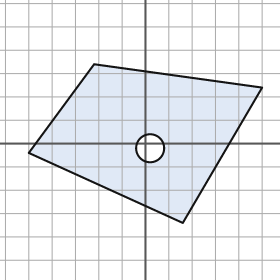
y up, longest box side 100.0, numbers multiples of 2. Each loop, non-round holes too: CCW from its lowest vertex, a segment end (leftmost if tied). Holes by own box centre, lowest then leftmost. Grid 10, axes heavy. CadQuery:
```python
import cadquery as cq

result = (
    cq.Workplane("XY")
    .moveTo(16.0, -34.0)
    .lineTo(50.0, 24.0)
    .lineTo(-22.0, 34.0)
    .lineTo(-50.0, -4.0)
    .close()
    .moveTo(2.0, -2.0)
    .circle(6.0)
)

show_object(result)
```